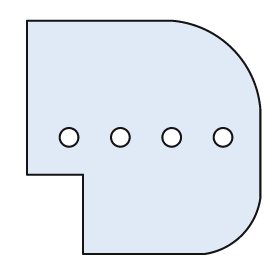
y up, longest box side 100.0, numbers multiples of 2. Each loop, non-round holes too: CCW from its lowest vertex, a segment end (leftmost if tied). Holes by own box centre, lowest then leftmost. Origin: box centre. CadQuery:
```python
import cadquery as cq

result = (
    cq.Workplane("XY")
    .moveTo(-26.0, -50.0)
    .lineTo(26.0, -50.0)
    .threePointArc((42.0, -42.0), (50.0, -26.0))
    .lineTo(50.0, 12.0)
    .threePointArc((38.0, 38.0), (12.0, 50.0))
    .lineTo(-50.0, 50.0)
    .lineTo(-50.0, -16.0)
    .lineTo(-26.0, -16.0)
    .close()
    .moveTo(-32.0, 0.0)
    .circle(4.0)
    .moveTo(-10.0, 0.0)
    .circle(4.0)
    .moveTo(12.0, 0.0)
    .circle(4.0)
    .moveTo(34.0, 0.0)
    .circle(4.0)
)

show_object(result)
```